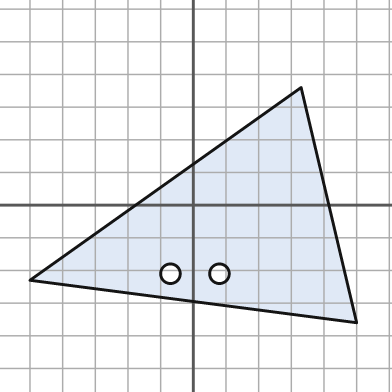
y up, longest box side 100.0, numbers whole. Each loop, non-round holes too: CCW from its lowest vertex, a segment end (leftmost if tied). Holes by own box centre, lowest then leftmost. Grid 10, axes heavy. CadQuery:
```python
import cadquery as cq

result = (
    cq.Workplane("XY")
    .moveTo(50.0, -36.0)
    .lineTo(33.0, 36.0)
    .lineTo(-50.0, -23.0)
    .close()
    .moveTo(-7.0, -21.0)
    .circle(3.0)
    .moveTo(8.0, -21.0)
    .circle(3.0)
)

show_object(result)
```